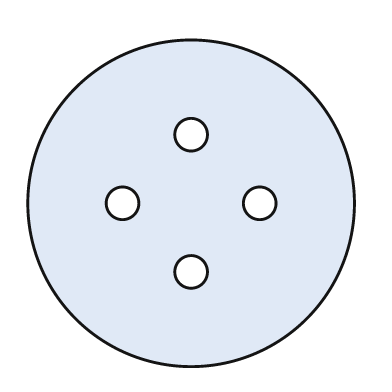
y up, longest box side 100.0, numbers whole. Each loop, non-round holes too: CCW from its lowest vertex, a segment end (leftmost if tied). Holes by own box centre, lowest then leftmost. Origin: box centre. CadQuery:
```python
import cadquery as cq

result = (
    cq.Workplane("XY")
    .moveTo(0.0, 0.0)
    .circle(50.0)
    .moveTo(0.0, -21.0)
    .circle(5.0)
    .moveTo(-21.0, 0.0)
    .circle(5.0)
    .moveTo(21.0, 0.0)
    .circle(5.0)
    .moveTo(0.0, 21.0)
    .circle(5.0)
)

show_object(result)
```